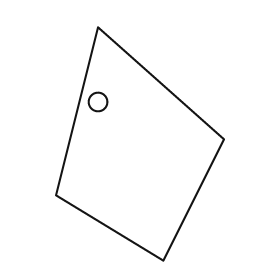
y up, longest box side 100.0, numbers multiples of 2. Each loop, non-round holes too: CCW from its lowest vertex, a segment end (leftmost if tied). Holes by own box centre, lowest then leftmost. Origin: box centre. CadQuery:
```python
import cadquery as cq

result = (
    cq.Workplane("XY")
    .moveTo(10.0, -50.0)
    .lineTo(36.0, 2.0)
    .lineTo(-18.0, 50.0)
    .lineTo(-36.0, -22.0)
    .close()
    .moveTo(-18.0, 18.0)
    .circle(4.0)
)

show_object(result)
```